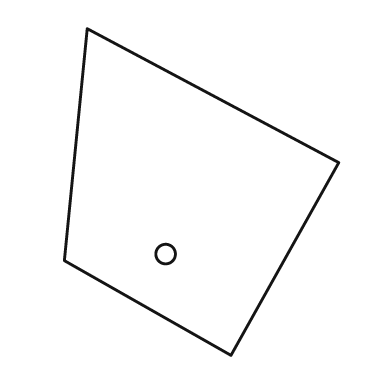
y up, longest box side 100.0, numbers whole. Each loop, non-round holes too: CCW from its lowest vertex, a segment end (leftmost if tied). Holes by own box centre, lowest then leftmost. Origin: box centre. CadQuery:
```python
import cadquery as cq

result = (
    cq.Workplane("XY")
    .moveTo(9.0, -50.0)
    .lineTo(42.0, 9.0)
    .lineTo(-35.0, 50.0)
    .lineTo(-42.0, -21.0)
    .close()
    .moveTo(-11.0, -19.0)
    .circle(3.0)
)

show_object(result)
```